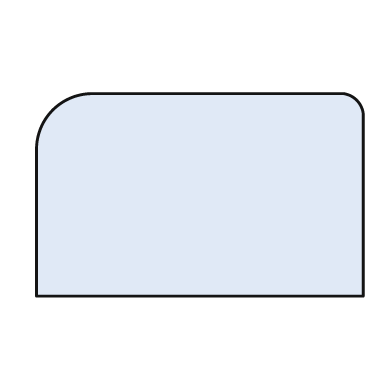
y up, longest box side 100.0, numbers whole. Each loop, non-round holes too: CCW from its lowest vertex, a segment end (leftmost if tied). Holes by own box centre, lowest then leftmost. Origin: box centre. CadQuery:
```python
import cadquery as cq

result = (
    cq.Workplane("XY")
    .moveTo(-50.0, -31.0)
    .lineTo(50.0, -31.0)
    .lineTo(50.0, 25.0)
    .threePointArc((48.0, 29.0), (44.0, 31.0))
    .lineTo(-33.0, 31.0)
    .threePointArc((-45.0, 26.0), (-50.0, 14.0))
    .close()
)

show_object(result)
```